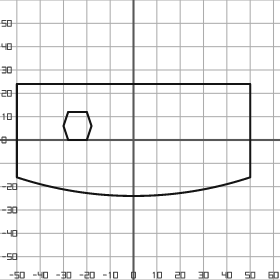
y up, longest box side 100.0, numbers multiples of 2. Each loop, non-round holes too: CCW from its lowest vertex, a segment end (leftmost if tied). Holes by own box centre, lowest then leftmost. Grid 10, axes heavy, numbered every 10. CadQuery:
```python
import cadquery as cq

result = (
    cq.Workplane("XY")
    .moveTo(-50.0, -16.0)
    .threePointArc((0.0, -24.0), (50.0, -16.0))
    .lineTo(50.0, 24.0)
    .lineTo(-50.0, 24.0)
    .close()
    .moveTo(-28.0, 0.0)
    .lineTo(-20.0, 0.0)
    .lineTo(-18.0, 6.0)
    .lineTo(-20.0, 12.0)
    .lineTo(-28.0, 12.0)
    .lineTo(-30.0, 6.0)
    .close()
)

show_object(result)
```